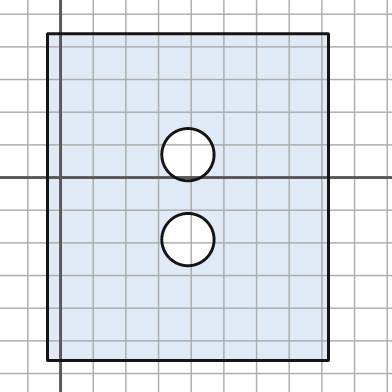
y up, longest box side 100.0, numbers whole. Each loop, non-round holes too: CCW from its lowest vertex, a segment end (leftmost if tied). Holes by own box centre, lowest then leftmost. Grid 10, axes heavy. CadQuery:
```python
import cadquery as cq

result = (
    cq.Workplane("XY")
    .moveTo(-4.0, -56.0)
    .lineTo(82.0, -56.0)
    .lineTo(82.0, 44.0)
    .lineTo(-4.0, 44.0)
    .close()
    .moveTo(39.0, -19.0)
    .circle(8.0)
    .moveTo(39.0, 7.0)
    .circle(8.0)
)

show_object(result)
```